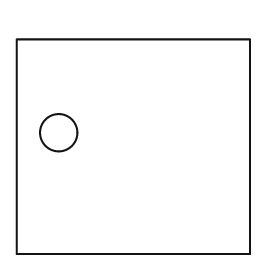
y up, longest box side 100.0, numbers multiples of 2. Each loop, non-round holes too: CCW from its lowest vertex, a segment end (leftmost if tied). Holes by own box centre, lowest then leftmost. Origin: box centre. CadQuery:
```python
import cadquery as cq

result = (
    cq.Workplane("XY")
    .moveTo(-50.0, -46.0)
    .lineTo(50.0, -46.0)
    .lineTo(50.0, 46.0)
    .lineTo(-50.0, 46.0)
    .close()
    .moveTo(-32.0, 6.0)
    .circle(8.0)
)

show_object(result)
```